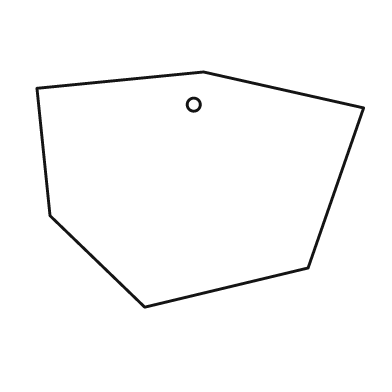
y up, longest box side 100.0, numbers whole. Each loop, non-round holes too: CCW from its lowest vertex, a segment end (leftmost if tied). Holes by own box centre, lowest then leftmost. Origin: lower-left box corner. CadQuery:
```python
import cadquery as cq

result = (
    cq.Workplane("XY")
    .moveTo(33.0, 0.0)
    .lineTo(83.0, 12.0)
    .lineTo(100.0, 61.0)
    .lineTo(51.0, 72.0)
    .lineTo(0.0, 67.0)
    .lineTo(4.0, 28.0)
    .close()
    .moveTo(48.0, 62.0)
    .circle(2.0)
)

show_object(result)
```